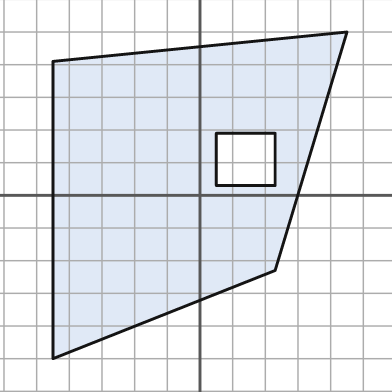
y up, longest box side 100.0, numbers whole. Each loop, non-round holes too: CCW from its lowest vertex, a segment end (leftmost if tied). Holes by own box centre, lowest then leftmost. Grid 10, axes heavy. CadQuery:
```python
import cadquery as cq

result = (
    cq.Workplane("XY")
    .moveTo(-45.0, -50.0)
    .lineTo(23.0, -23.0)
    .lineTo(45.0, 50.0)
    .lineTo(-45.0, 41.0)
    .close()
    .moveTo(5.0, 3.0)
    .lineTo(23.0, 3.0)
    .lineTo(23.0, 19.0)
    .lineTo(5.0, 19.0)
    .close()
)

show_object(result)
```